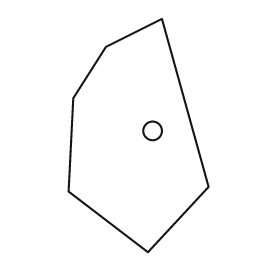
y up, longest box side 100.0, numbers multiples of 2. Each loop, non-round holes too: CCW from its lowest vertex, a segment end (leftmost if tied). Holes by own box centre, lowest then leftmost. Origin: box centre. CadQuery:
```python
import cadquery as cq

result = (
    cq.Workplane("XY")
    .moveTo(4.0, -50.0)
    .lineTo(30.0, -22.0)
    .lineTo(10.0, 50.0)
    .lineTo(-14.0, 38.0)
    .lineTo(-28.0, 16.0)
    .lineTo(-30.0, -24.0)
    .close()
    .moveTo(6.0, 2.0)
    .circle(4.0)
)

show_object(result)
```